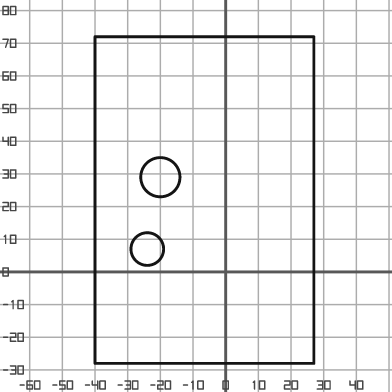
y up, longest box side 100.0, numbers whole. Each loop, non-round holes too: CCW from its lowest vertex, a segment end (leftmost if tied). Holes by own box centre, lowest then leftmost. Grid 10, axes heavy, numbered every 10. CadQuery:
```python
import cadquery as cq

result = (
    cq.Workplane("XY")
    .moveTo(-40.0, -28.0)
    .lineTo(27.0, -28.0)
    .lineTo(27.0, 72.0)
    .lineTo(-40.0, 72.0)
    .close()
    .moveTo(-24.0, 7.0)
    .circle(5.0)
    .moveTo(-20.0, 29.0)
    .circle(6.0)
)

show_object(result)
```